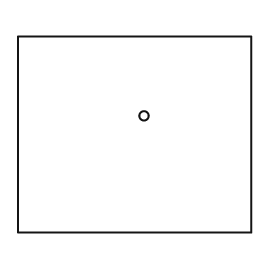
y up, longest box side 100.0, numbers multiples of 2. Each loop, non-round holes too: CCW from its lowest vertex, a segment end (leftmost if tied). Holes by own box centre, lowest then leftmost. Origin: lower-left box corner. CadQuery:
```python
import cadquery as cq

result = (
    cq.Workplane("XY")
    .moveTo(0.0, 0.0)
    .lineTo(100.0, 0.0)
    .lineTo(100.0, 84.0)
    .lineTo(0.0, 84.0)
    .close()
    .moveTo(54.0, 50.0)
    .circle(2.0)
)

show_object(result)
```